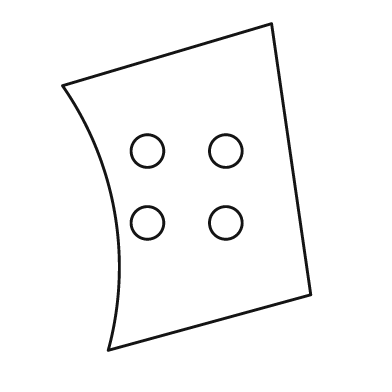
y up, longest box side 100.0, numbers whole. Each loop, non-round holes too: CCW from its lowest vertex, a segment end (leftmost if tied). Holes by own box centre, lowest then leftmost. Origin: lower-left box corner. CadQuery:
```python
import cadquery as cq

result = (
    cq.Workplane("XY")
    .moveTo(14.0, 0.0)
    .lineTo(76.0, 17.0)
    .lineTo(64.0, 100.0)
    .lineTo(0.0, 81.0)
    .threePointArc((16.0, 42.0), (14.0, 0.0))
    .close()
    .moveTo(26.0, 39.0)
    .circle(5.0)
    .moveTo(50.0, 39.0)
    .circle(5.0)
    .moveTo(26.0, 61.0)
    .circle(5.0)
    .moveTo(50.0, 61.0)
    .circle(5.0)
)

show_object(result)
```